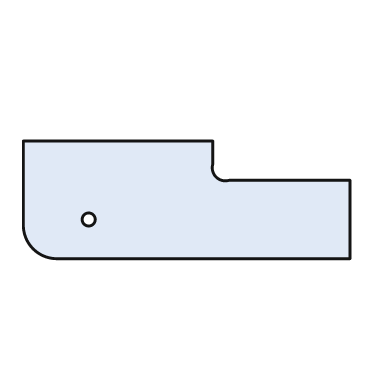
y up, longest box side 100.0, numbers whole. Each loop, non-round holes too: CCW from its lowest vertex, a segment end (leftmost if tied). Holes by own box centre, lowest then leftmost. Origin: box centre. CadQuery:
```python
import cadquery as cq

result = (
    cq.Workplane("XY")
    .moveTo(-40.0, -18.0)
    .lineTo(50.0, -18.0)
    .lineTo(50.0, 6.0)
    .lineTo(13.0, 6.0)
    .threePointArc((9.0, 7.0), (8.0, 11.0))
    .lineTo(8.0, 18.0)
    .lineTo(-50.0, 18.0)
    .lineTo(-50.0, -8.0)
    .threePointArc((-47.0, -15.0), (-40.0, -18.0))
    .close()
    .moveTo(-30.0, -6.0)
    .circle(2.0)
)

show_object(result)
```